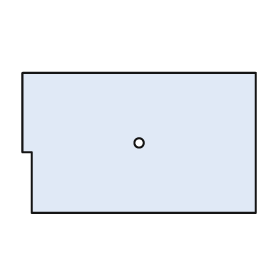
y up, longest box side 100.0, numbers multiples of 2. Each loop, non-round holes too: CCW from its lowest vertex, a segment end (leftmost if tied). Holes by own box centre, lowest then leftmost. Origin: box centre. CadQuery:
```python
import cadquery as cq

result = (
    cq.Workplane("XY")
    .moveTo(-46.0, -30.0)
    .lineTo(50.0, -30.0)
    .lineTo(50.0, 30.0)
    .lineTo(-50.0, 30.0)
    .lineTo(-50.0, -4.0)
    .lineTo(-46.0, -4.0)
    .close()
    .moveTo(0.0, 0.0)
    .circle(2.0)
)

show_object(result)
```